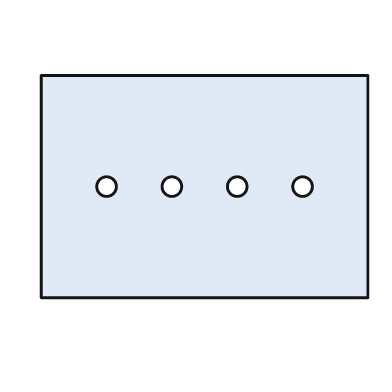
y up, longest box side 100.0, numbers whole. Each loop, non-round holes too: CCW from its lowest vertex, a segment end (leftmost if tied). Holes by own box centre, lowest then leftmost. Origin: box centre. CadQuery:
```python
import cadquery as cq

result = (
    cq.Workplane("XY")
    .moveTo(-50.0, -34.0)
    .lineTo(50.0, -34.0)
    .lineTo(50.0, 34.0)
    .lineTo(-50.0, 34.0)
    .close()
    .moveTo(-30.0, 0.0)
    .circle(3.0)
    .moveTo(-10.0, 0.0)
    .circle(3.0)
    .moveTo(10.0, 0.0)
    .circle(3.0)
    .moveTo(30.0, 0.0)
    .circle(3.0)
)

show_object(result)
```